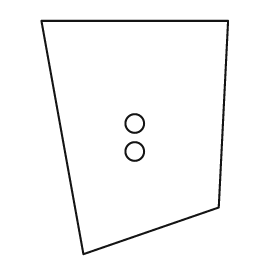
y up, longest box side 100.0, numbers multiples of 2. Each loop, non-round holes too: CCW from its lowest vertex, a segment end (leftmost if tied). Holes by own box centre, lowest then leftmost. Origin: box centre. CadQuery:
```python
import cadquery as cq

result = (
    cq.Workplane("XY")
    .moveTo(-22.0, -50.0)
    .lineTo(36.0, -30.0)
    .lineTo(40.0, 50.0)
    .lineTo(-40.0, 50.0)
    .close()
    .moveTo(0.0, -6.0)
    .circle(4.0)
    .moveTo(0.0, 6.0)
    .circle(4.0)
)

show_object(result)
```